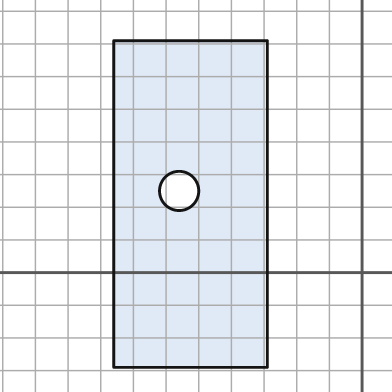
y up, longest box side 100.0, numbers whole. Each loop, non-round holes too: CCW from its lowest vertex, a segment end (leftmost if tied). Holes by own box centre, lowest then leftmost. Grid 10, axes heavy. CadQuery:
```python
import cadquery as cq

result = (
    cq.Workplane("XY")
    .moveTo(-76.0, -29.0)
    .lineTo(-29.0, -29.0)
    .lineTo(-29.0, 71.0)
    .lineTo(-76.0, 71.0)
    .close()
    .moveTo(-56.0, 25.0)
    .circle(6.0)
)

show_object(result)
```